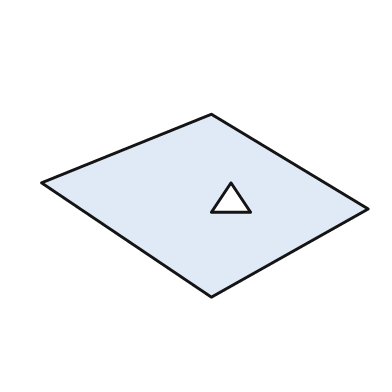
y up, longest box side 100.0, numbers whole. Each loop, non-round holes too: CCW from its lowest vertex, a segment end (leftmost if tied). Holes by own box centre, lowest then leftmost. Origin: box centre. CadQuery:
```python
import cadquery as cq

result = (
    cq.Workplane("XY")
    .moveTo(2.0, -28.0)
    .lineTo(50.0, -1.0)
    .lineTo(2.0, 28.0)
    .lineTo(-50.0, 7.0)
    .close()
    .moveTo(2.0, -2.0)
    .lineTo(14.0, -2.0)
    .lineTo(8.0, 7.0)
    .close()
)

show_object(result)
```